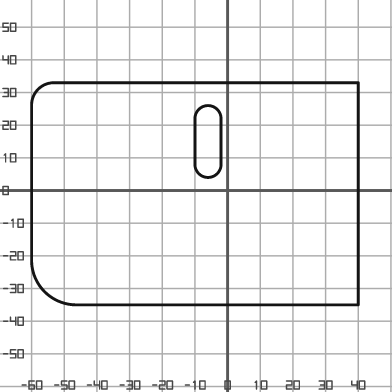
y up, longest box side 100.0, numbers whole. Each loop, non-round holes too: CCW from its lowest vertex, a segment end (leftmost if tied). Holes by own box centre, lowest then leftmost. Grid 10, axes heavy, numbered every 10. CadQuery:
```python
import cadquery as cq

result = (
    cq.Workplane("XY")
    .moveTo(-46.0, -35.0)
    .lineTo(40.0, -35.0)
    .lineTo(40.0, 33.0)
    .lineTo(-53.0, 33.0)
    .threePointArc((-58.0, 31.0), (-60.0, 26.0))
    .lineTo(-60.0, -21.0)
    .threePointArc((-56.0, -31.0), (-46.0, -35.0))
    .close()
    .moveTo(-10.0, 8.0)
    .threePointArc((-6.0, 4.0), (-2.0, 8.0))
    .lineTo(-2.0, 22.0)
    .threePointArc((-6.0, 26.0), (-10.0, 22.0))
    .close()
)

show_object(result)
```